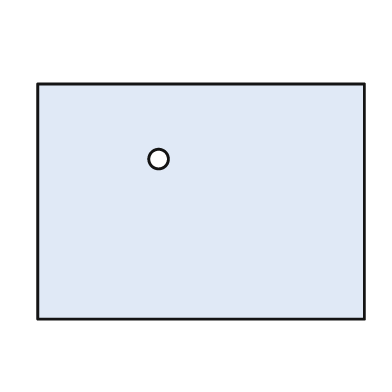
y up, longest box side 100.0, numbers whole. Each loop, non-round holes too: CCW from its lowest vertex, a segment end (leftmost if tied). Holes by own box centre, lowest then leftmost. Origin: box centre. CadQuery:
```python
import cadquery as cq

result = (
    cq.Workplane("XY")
    .moveTo(-50.0, -36.0)
    .lineTo(50.0, -36.0)
    .lineTo(50.0, 36.0)
    .lineTo(-50.0, 36.0)
    .close()
    .moveTo(-13.0, 13.0)
    .circle(3.0)
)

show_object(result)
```